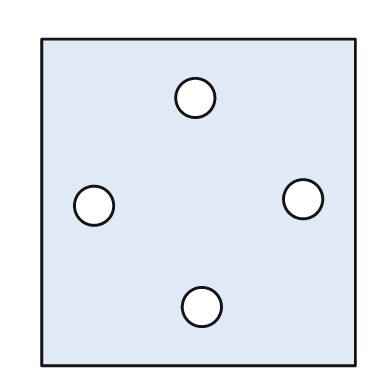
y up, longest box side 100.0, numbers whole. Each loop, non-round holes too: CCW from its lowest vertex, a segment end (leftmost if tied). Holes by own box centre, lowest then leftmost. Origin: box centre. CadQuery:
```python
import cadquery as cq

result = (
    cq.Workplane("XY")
    .moveTo(-48.0, -50.0)
    .lineTo(48.0, -50.0)
    .lineTo(48.0, 50.0)
    .lineTo(-48.0, 50.0)
    .close()
    .moveTo(1.0, -32.0)
    .circle(6.0)
    .moveTo(-32.0, -1.0)
    .circle(6.0)
    .moveTo(32.0, 1.0)
    .circle(6.0)
    .moveTo(-1.0, 32.0)
    .circle(6.0)
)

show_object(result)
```